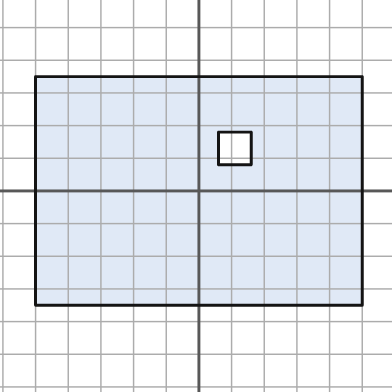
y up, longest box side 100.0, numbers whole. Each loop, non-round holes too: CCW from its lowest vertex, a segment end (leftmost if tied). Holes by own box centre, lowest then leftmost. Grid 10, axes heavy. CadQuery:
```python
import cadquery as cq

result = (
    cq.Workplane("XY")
    .moveTo(-50.0, -35.0)
    .lineTo(50.0, -35.0)
    .lineTo(50.0, 35.0)
    .lineTo(-50.0, 35.0)
    .close()
    .moveTo(6.0, 8.0)
    .lineTo(16.0, 8.0)
    .lineTo(16.0, 18.0)
    .lineTo(6.0, 18.0)
    .close()
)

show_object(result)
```